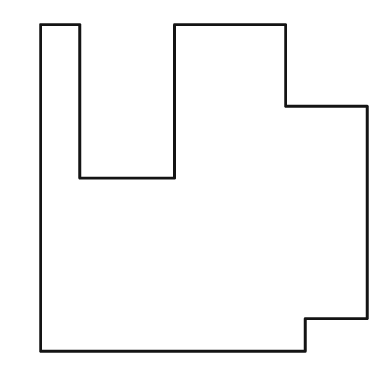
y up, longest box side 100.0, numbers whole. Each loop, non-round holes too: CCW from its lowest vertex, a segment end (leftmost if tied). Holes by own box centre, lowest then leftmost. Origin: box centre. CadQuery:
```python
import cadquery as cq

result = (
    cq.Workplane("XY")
    .moveTo(-50.0, -50.0)
    .lineTo(31.0, -50.0)
    .lineTo(31.0, -40.0)
    .lineTo(50.0, -40.0)
    .lineTo(50.0, 25.0)
    .lineTo(25.0, 25.0)
    .lineTo(25.0, 50.0)
    .lineTo(-9.0, 50.0)
    .lineTo(-9.0, 3.0)
    .lineTo(-38.0, 3.0)
    .lineTo(-38.0, 50.0)
    .lineTo(-50.0, 50.0)
    .close()
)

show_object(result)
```